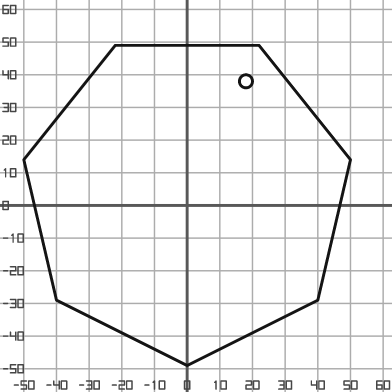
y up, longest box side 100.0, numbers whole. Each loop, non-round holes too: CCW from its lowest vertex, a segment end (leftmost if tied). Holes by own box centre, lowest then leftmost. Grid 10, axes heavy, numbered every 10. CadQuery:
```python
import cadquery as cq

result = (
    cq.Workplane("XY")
    .moveTo(0.0, -49.0)
    .lineTo(40.0, -29.0)
    .lineTo(50.0, 14.0)
    .lineTo(22.0, 49.0)
    .lineTo(-22.0, 49.0)
    .lineTo(-50.0, 14.0)
    .lineTo(-40.0, -29.0)
    .close()
    .moveTo(18.0, 38.0)
    .circle(2.0)
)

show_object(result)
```